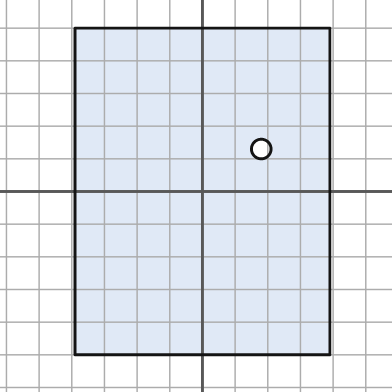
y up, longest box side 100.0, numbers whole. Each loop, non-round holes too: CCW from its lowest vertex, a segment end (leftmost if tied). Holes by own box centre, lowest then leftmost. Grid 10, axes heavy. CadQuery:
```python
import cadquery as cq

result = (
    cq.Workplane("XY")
    .moveTo(-39.0, -50.0)
    .lineTo(39.0, -50.0)
    .lineTo(39.0, 50.0)
    .lineTo(-39.0, 50.0)
    .close()
    .moveTo(18.0, 13.0)
    .circle(3.0)
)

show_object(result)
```